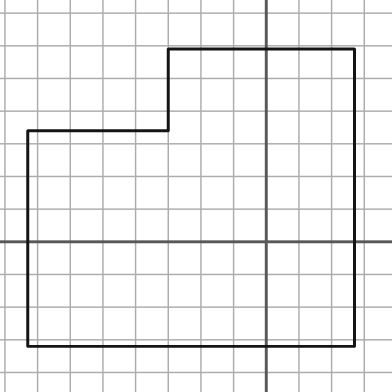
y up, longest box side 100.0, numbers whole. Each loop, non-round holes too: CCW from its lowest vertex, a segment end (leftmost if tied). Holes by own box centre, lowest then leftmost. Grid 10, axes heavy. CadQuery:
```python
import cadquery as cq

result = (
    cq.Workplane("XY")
    .moveTo(-73.0, -32.0)
    .lineTo(27.0, -32.0)
    .lineTo(27.0, 59.0)
    .lineTo(-30.0, 59.0)
    .lineTo(-30.0, 34.0)
    .lineTo(-73.0, 34.0)
    .close()
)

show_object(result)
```